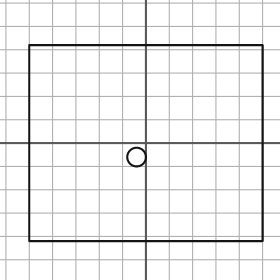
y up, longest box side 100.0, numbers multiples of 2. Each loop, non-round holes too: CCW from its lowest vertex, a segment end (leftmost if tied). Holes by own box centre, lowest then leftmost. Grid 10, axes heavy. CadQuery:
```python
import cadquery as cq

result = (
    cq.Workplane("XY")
    .moveTo(-50.0, -42.0)
    .lineTo(50.0, -42.0)
    .lineTo(50.0, 42.0)
    .lineTo(-50.0, 42.0)
    .close()
    .moveTo(-4.0, -6.0)
    .circle(4.0)
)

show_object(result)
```